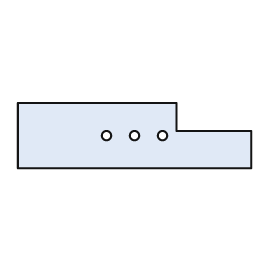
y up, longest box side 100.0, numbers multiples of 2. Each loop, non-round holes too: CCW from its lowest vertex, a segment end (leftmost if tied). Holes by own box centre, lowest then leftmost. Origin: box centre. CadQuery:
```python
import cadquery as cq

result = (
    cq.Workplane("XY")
    .moveTo(-50.0, -14.0)
    .lineTo(50.0, -14.0)
    .lineTo(50.0, 2.0)
    .lineTo(18.0, 2.0)
    .lineTo(18.0, 14.0)
    .lineTo(-50.0, 14.0)
    .close()
    .moveTo(-12.0, 0.0)
    .circle(2.0)
    .moveTo(0.0, 0.0)
    .circle(2.0)
    .moveTo(12.0, 0.0)
    .circle(2.0)
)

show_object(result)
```